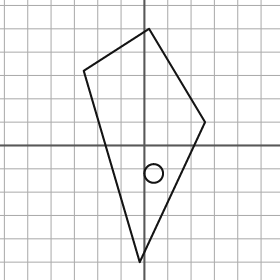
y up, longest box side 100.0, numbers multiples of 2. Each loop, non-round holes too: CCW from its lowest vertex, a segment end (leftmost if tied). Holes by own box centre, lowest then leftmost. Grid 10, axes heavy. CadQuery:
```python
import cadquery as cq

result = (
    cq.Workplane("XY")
    .moveTo(-2.0, -50.0)
    .lineTo(26.0, 10.0)
    .lineTo(2.0, 50.0)
    .lineTo(-26.0, 32.0)
    .close()
    .moveTo(4.0, -12.0)
    .circle(4.0)
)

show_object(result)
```